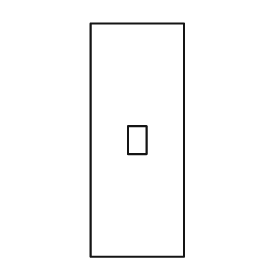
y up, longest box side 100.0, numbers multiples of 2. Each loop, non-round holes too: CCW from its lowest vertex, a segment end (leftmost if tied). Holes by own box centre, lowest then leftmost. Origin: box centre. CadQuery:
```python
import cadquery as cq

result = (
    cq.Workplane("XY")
    .moveTo(-20.0, -50.0)
    .lineTo(20.0, -50.0)
    .lineTo(20.0, 50.0)
    .lineTo(-20.0, 50.0)
    .close()
    .moveTo(-4.0, -6.0)
    .lineTo(4.0, -6.0)
    .lineTo(4.0, 6.0)
    .lineTo(-4.0, 6.0)
    .close()
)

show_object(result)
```